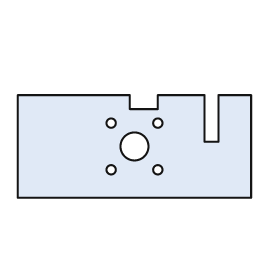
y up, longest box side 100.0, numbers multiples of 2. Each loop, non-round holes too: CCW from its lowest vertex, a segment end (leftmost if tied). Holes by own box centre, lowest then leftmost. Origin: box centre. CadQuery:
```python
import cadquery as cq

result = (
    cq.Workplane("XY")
    .moveTo(-50.0, -22.0)
    .lineTo(50.0, -22.0)
    .lineTo(50.0, 22.0)
    .lineTo(36.0, 22.0)
    .lineTo(36.0, 2.0)
    .lineTo(30.0, 2.0)
    .lineTo(30.0, 22.0)
    .lineTo(10.0, 22.0)
    .lineTo(10.0, 16.0)
    .lineTo(-2.0, 16.0)
    .lineTo(-2.0, 22.0)
    .lineTo(-50.0, 22.0)
    .close()
    .moveTo(-10.0, -10.0)
    .circle(2.0)
    .moveTo(10.0, -10.0)
    .circle(2.0)
    .moveTo(0.0, 0.0)
    .circle(6.0)
    .moveTo(-10.0, 10.0)
    .circle(2.0)
    .moveTo(10.0, 10.0)
    .circle(2.0)
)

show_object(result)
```